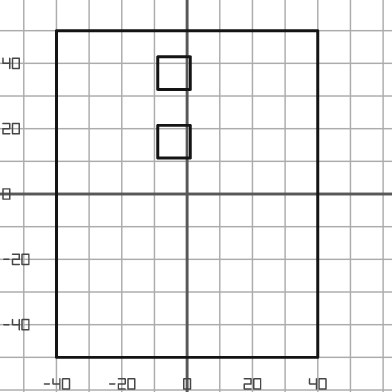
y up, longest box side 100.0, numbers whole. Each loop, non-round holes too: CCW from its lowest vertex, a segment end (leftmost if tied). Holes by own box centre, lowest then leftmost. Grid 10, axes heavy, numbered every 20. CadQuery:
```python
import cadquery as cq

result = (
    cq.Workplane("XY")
    .moveTo(-40.0, -50.0)
    .lineTo(40.0, -50.0)
    .lineTo(40.0, 50.0)
    .lineTo(-40.0, 50.0)
    .close()
    .moveTo(-9.0, 11.0)
    .lineTo(1.0, 11.0)
    .lineTo(1.0, 21.0)
    .lineTo(-9.0, 21.0)
    .close()
    .moveTo(-9.0, 32.0)
    .lineTo(1.0, 32.0)
    .lineTo(1.0, 42.0)
    .lineTo(-9.0, 42.0)
    .close()
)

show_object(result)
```